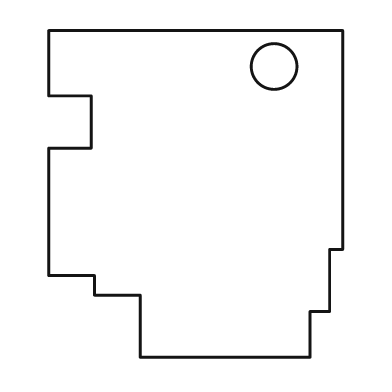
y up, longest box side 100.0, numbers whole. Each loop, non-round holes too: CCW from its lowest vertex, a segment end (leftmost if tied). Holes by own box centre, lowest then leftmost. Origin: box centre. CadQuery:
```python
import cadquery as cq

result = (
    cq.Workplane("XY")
    .moveTo(-17.0, -50.0)
    .lineTo(35.0, -50.0)
    .lineTo(35.0, -36.0)
    .lineTo(41.0, -36.0)
    .lineTo(41.0, -17.0)
    .lineTo(45.0, -17.0)
    .lineTo(45.0, 50.0)
    .lineTo(-45.0, 50.0)
    .lineTo(-45.0, 30.0)
    .lineTo(-32.0, 30.0)
    .lineTo(-32.0, 14.0)
    .lineTo(-45.0, 14.0)
    .lineTo(-45.0, -25.0)
    .lineTo(-31.0, -25.0)
    .lineTo(-31.0, -31.0)
    .lineTo(-17.0, -31.0)
    .close()
    .moveTo(24.0, 39.0)
    .circle(7.0)
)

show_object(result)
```